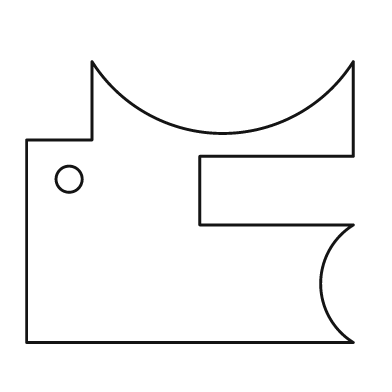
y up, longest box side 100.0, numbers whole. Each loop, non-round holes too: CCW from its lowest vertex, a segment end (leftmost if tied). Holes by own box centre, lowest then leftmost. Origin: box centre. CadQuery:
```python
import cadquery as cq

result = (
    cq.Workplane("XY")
    .moveTo(-50.0, -43.0)
    .lineTo(50.0, -43.0)
    .threePointArc((40.0, -25.0), (50.0, -7.0))
    .lineTo(3.0, -7.0)
    .lineTo(3.0, 14.0)
    .lineTo(50.0, 14.0)
    .lineTo(50.0, 43.0)
    .threePointArc((10.0, 21.0), (-30.0, 43.0))
    .lineTo(-30.0, 19.0)
    .lineTo(-50.0, 19.0)
    .close()
    .moveTo(-37.0, 7.0)
    .circle(4.0)
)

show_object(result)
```